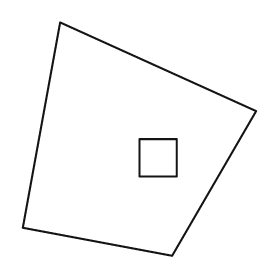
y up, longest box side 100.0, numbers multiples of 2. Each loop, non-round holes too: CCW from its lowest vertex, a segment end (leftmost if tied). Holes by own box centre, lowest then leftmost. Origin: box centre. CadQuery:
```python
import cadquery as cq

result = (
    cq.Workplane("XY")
    .moveTo(14.0, -50.0)
    .lineTo(50.0, 12.0)
    .lineTo(-34.0, 50.0)
    .lineTo(-50.0, -38.0)
    .close()
    .moveTo(0.0, -16.0)
    .lineTo(16.0, -16.0)
    .lineTo(16.0, 0.0)
    .lineTo(0.0, 0.0)
    .close()
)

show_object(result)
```